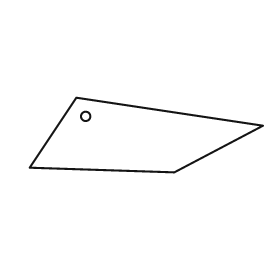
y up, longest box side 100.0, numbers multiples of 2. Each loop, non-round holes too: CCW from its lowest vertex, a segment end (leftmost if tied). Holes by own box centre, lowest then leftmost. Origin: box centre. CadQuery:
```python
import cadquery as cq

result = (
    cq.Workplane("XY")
    .moveTo(12.0, -16.0)
    .lineTo(50.0, 4.0)
    .lineTo(-30.0, 16.0)
    .lineTo(-50.0, -14.0)
    .close()
    .moveTo(-26.0, 8.0)
    .circle(2.0)
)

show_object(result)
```